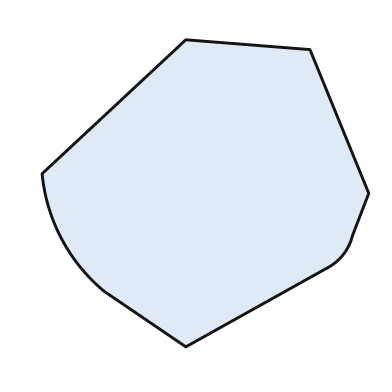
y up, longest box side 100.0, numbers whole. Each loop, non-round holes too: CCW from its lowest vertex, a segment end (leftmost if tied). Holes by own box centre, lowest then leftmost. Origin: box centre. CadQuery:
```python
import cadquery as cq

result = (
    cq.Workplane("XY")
    .moveTo(-6.0, -47.0)
    .lineTo(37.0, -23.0)
    .threePointArc((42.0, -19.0), (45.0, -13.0))
    .lineTo(50.0, 0.0)
    .lineTo(32.0, 44.0)
    .lineTo(-6.0, 47.0)
    .lineTo(-50.0, 6.0)
    .threePointArc((-44.0, -14.0), (-31.0, -30.0))
    .close()
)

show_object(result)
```